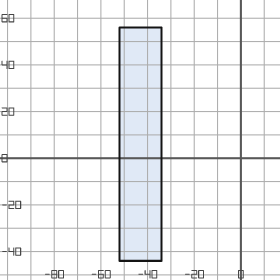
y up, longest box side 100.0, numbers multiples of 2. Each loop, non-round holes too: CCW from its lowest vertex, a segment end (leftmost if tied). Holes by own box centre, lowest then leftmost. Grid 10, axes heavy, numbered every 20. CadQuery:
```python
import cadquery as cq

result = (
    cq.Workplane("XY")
    .moveTo(-52.0, -44.0)
    .lineTo(-34.0, -44.0)
    .lineTo(-34.0, 56.0)
    .lineTo(-52.0, 56.0)
    .close()
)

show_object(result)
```